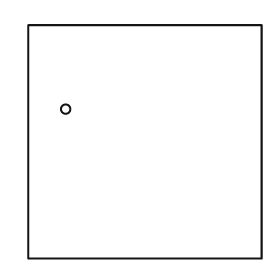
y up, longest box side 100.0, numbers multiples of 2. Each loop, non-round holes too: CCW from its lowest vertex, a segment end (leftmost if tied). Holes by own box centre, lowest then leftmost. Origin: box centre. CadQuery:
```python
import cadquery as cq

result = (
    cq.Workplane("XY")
    .moveTo(-50.0, -50.0)
    .lineTo(50.0, -50.0)
    .lineTo(50.0, 50.0)
    .lineTo(-50.0, 50.0)
    .close()
    .moveTo(-34.0, 14.0)
    .circle(2.0)
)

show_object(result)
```